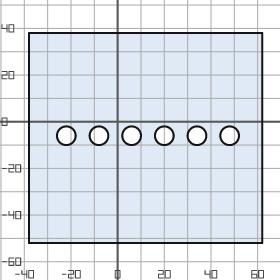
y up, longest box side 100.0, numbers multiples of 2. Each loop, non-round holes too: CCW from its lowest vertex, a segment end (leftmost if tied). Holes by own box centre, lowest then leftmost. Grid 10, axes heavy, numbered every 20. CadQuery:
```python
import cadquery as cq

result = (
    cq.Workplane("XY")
    .moveTo(-38.0, -52.0)
    .lineTo(62.0, -52.0)
    .lineTo(62.0, 38.0)
    .lineTo(-38.0, 38.0)
    .close()
    .moveTo(-22.0, -6.0)
    .circle(4.0)
    .moveTo(-8.0, -6.0)
    .circle(4.0)
    .moveTo(6.0, -6.0)
    .circle(4.0)
    .moveTo(20.0, -6.0)
    .circle(4.0)
    .moveTo(34.0, -6.0)
    .circle(4.0)
    .moveTo(48.0, -6.0)
    .circle(4.0)
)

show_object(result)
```